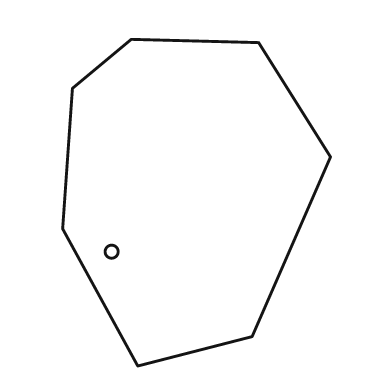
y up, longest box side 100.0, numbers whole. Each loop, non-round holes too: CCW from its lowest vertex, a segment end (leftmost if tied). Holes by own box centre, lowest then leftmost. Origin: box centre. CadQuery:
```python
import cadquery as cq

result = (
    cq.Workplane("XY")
    .moveTo(-18.0, -50.0)
    .lineTo(17.0, -41.0)
    .lineTo(41.0, 14.0)
    .lineTo(19.0, 49.0)
    .lineTo(-20.0, 50.0)
    .lineTo(-38.0, 35.0)
    .lineTo(-41.0, -8.0)
    .close()
    .moveTo(-26.0, -15.0)
    .circle(2.0)
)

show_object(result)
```